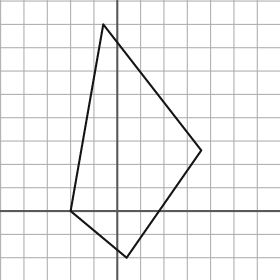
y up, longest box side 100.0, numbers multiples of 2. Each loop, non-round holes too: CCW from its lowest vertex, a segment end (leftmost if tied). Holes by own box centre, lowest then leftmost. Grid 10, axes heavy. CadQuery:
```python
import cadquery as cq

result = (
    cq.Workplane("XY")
    .moveTo(4.0, -20.0)
    .lineTo(36.0, 26.0)
    .lineTo(-6.0, 80.0)
    .lineTo(-20.0, 0.0)
    .close()
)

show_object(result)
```